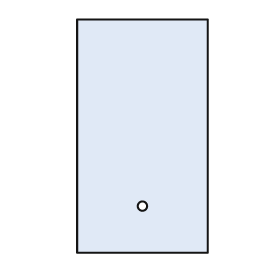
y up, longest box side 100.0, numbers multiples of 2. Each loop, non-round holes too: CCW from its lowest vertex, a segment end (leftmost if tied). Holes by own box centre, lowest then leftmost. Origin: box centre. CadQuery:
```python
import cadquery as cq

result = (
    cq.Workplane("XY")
    .moveTo(-28.0, -50.0)
    .lineTo(28.0, -50.0)
    .lineTo(28.0, 50.0)
    .lineTo(-28.0, 50.0)
    .close()
    .moveTo(0.0, -30.0)
    .circle(2.0)
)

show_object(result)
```